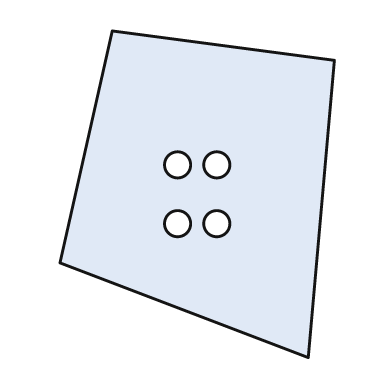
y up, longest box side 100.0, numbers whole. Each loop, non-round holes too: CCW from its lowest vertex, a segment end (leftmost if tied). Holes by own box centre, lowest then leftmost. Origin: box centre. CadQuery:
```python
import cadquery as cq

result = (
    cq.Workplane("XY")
    .moveTo(34.0, -50.0)
    .lineTo(42.0, 41.0)
    .lineTo(-26.0, 50.0)
    .lineTo(-42.0, -21.0)
    .close()
    .moveTo(-6.0, -9.0)
    .circle(4.0)
    .moveTo(6.0, -9.0)
    .circle(4.0)
    .moveTo(-6.0, 9.0)
    .circle(4.0)
    .moveTo(6.0, 9.0)
    .circle(4.0)
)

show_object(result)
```